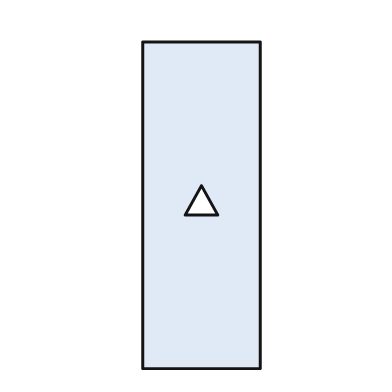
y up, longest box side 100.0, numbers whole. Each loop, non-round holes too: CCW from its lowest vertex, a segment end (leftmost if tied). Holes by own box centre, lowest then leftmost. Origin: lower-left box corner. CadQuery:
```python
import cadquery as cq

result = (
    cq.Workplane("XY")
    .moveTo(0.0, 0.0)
    .lineTo(36.0, 0.0)
    .lineTo(36.0, 100.0)
    .lineTo(0.0, 100.0)
    .close()
    .moveTo(13.0, 47.0)
    .lineTo(23.0, 47.0)
    .lineTo(18.0, 56.0)
    .close()
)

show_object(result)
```